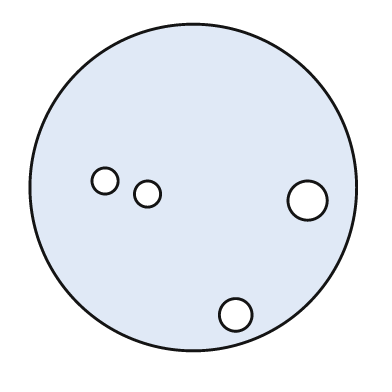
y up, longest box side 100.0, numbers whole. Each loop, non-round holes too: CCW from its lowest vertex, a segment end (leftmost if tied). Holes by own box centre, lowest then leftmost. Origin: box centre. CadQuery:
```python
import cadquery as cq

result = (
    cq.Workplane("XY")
    .moveTo(0.0, 0.0)
    .circle(50.0)
    .moveTo(13.0, -39.0)
    .circle(5.0)
    .moveTo(35.0, -4.0)
    .circle(6.0)
    .moveTo(-14.0, -2.0)
    .circle(4.0)
    .moveTo(-27.0, 2.0)
    .circle(4.0)
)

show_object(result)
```